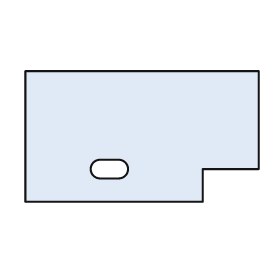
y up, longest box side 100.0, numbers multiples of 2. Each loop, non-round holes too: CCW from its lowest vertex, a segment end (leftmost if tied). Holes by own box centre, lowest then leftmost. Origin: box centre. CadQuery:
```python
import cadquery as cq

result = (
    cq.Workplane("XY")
    .moveTo(-50.0, -28.0)
    .lineTo(26.0, -28.0)
    .lineTo(26.0, -14.0)
    .lineTo(50.0, -14.0)
    .lineTo(50.0, 28.0)
    .lineTo(-50.0, 28.0)
    .close()
    .moveTo(-18.0, -18.0)
    .lineTo(-10.0, -18.0)
    .threePointArc((-6.0, -14.0), (-10.0, -10.0))
    .lineTo(-18.0, -10.0)
    .threePointArc((-22.0, -14.0), (-18.0, -18.0))
    .close()
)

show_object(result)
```